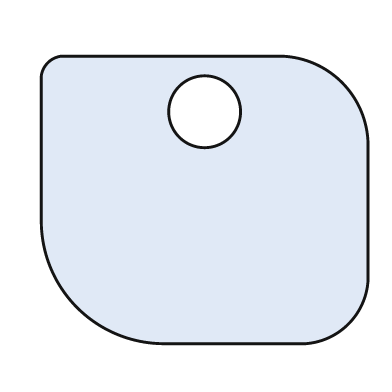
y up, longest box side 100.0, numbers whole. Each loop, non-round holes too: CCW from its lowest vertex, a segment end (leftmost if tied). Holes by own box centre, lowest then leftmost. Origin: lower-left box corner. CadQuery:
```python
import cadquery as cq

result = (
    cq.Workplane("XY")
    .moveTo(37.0, 0.0)
    .lineTo(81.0, 0.0)
    .threePointArc((94.0, 6.0), (100.0, 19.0))
    .lineTo(100.0, 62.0)
    .threePointArc((92.0, 80.0), (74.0, 88.0))
    .lineTo(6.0, 88.0)
    .threePointArc((2.0, 86.0), (0.0, 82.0))
    .lineTo(0.0, 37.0)
    .threePointArc((11.0, 11.0), (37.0, 0.0))
    .close()
    .moveTo(50.0, 71.0)
    .circle(11.0)
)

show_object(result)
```